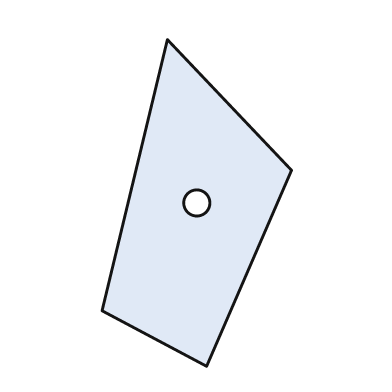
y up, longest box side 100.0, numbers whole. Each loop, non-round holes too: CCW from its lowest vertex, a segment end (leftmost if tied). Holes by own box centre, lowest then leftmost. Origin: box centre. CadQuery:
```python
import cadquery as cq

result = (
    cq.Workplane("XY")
    .moveTo(3.0, -50.0)
    .lineTo(29.0, 10.0)
    .lineTo(-9.0, 50.0)
    .lineTo(-29.0, -33.0)
    .close()
    .moveTo(0.0, 0.0)
    .circle(4.0)
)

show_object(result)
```